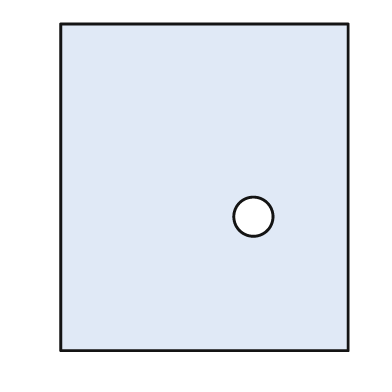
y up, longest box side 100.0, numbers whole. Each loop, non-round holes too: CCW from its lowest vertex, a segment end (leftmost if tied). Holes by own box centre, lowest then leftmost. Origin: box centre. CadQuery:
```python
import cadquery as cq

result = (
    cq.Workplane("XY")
    .moveTo(-44.0, -50.0)
    .lineTo(44.0, -50.0)
    .lineTo(44.0, 50.0)
    .lineTo(-44.0, 50.0)
    .close()
    .moveTo(15.0, -9.0)
    .circle(6.0)
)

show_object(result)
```